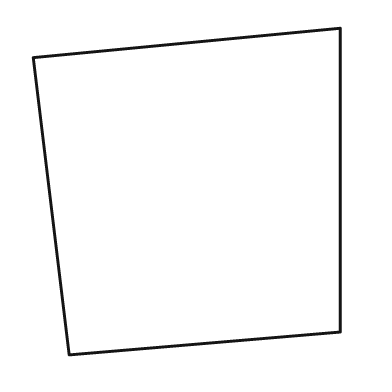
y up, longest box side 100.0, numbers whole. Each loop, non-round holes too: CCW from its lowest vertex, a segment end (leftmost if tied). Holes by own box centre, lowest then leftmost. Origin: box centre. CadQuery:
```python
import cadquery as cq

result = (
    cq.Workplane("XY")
    .moveTo(-36.0, -50.0)
    .lineTo(47.0, -43.0)
    .lineTo(47.0, 50.0)
    .lineTo(-47.0, 41.0)
    .close()
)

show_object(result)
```